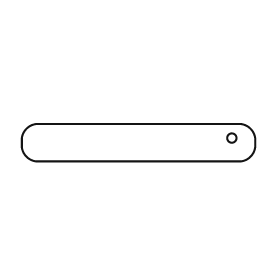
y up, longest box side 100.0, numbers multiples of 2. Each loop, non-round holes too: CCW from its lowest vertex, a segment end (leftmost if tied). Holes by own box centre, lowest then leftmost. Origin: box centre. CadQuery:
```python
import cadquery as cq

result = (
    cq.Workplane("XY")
    .moveTo(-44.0, -8.0)
    .lineTo(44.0, -8.0)
    .threePointArc((48.0, -6.0), (50.0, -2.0))
    .lineTo(50.0, 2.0)
    .threePointArc((48.0, 6.0), (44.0, 8.0))
    .lineTo(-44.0, 8.0)
    .threePointArc((-48.0, 6.0), (-50.0, 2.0))
    .lineTo(-50.0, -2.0)
    .threePointArc((-48.0, -6.0), (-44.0, -8.0))
    .close()
    .moveTo(40.0, 2.0)
    .circle(2.0)
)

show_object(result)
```